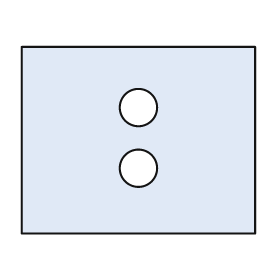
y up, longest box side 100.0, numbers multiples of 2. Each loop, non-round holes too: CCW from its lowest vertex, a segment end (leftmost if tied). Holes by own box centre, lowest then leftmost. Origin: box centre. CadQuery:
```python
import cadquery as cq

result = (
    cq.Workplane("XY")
    .moveTo(-50.0, -40.0)
    .lineTo(50.0, -40.0)
    .lineTo(50.0, 40.0)
    .lineTo(-50.0, 40.0)
    .close()
    .moveTo(0.0, -12.0)
    .circle(8.0)
    .moveTo(0.0, 14.0)
    .circle(8.0)
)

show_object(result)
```